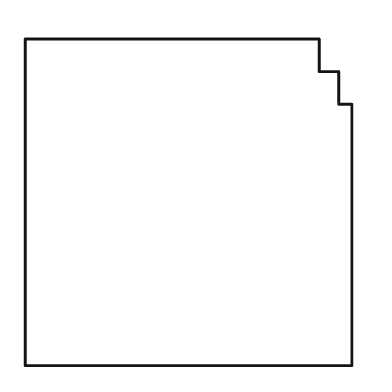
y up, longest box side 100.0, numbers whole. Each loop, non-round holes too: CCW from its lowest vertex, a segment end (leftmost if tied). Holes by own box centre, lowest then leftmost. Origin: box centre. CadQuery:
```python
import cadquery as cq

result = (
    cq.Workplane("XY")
    .moveTo(-50.0, -50.0)
    .lineTo(50.0, -50.0)
    .lineTo(50.0, 30.0)
    .lineTo(46.0, 30.0)
    .lineTo(46.0, 40.0)
    .lineTo(40.0, 40.0)
    .lineTo(40.0, 50.0)
    .lineTo(-50.0, 50.0)
    .close()
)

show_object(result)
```